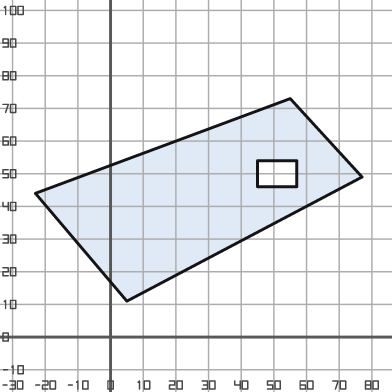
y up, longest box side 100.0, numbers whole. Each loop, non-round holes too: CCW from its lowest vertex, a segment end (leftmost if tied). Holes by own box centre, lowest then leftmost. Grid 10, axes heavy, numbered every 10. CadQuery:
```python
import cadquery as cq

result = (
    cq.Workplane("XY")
    .moveTo(5.0, 11.0)
    .lineTo(77.0, 49.0)
    .lineTo(55.0, 73.0)
    .lineTo(-23.0, 44.0)
    .close()
    .moveTo(45.0, 46.0)
    .lineTo(57.0, 46.0)
    .lineTo(57.0, 54.0)
    .lineTo(45.0, 54.0)
    .close()
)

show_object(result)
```